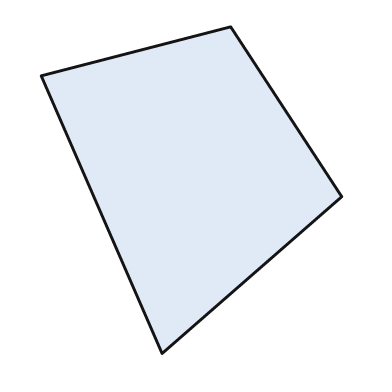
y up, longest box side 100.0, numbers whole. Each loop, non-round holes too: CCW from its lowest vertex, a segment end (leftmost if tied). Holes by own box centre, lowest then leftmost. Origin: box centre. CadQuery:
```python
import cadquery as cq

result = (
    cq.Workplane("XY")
    .moveTo(-9.0, -50.0)
    .lineTo(46.0, -2.0)
    .lineTo(12.0, 50.0)
    .lineTo(-46.0, 35.0)
    .close()
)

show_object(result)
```